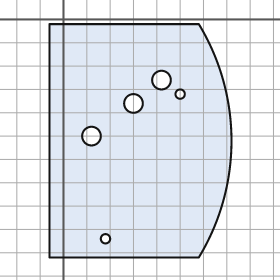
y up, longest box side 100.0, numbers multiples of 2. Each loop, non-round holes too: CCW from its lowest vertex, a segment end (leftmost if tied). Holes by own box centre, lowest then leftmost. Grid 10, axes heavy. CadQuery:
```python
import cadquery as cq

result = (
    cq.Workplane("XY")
    .moveTo(-6.0, -102.0)
    .lineTo(58.0, -102.0)
    .threePointArc((72.0, -52.0), (58.0, -2.0))
    .lineTo(-6.0, -2.0)
    .close()
    .moveTo(18.0, -94.0)
    .circle(2.0)
    .moveTo(12.0, -50.0)
    .circle(4.0)
    .moveTo(30.0, -36.0)
    .circle(4.0)
    .moveTo(50.0, -32.0)
    .circle(2.0)
    .moveTo(42.0, -26.0)
    .circle(4.0)
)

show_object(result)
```